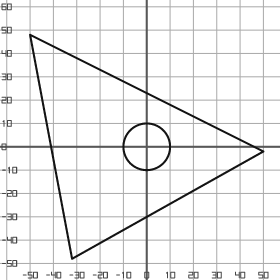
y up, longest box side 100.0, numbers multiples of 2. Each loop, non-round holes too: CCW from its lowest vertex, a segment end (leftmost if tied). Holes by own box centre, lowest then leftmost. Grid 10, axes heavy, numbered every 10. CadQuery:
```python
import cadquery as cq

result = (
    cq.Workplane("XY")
    .moveTo(-32.0, -48.0)
    .lineTo(50.0, -2.0)
    .lineTo(-50.0, 48.0)
    .close()
    .moveTo(0.0, 0.0)
    .circle(10.0)
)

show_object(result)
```